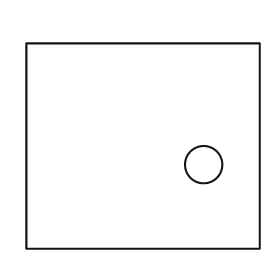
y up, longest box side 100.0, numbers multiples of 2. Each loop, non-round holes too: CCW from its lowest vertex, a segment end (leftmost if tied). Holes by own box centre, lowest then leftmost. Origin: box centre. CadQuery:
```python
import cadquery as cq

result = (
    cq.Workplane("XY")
    .moveTo(-50.0, -44.0)
    .lineTo(50.0, -44.0)
    .lineTo(50.0, 44.0)
    .lineTo(-50.0, 44.0)
    .close()
    .moveTo(26.0, -8.0)
    .circle(8.0)
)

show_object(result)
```